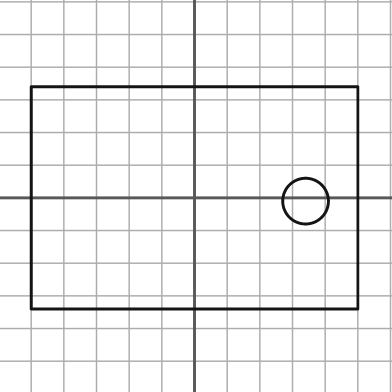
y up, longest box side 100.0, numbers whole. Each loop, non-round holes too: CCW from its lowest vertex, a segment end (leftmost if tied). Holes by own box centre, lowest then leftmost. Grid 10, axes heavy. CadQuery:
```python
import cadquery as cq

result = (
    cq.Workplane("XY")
    .moveTo(-50.0, -34.0)
    .lineTo(50.0, -34.0)
    .lineTo(50.0, 34.0)
    .lineTo(-50.0, 34.0)
    .close()
    .moveTo(34.0, -1.0)
    .circle(7.0)
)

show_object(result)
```